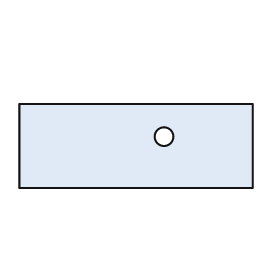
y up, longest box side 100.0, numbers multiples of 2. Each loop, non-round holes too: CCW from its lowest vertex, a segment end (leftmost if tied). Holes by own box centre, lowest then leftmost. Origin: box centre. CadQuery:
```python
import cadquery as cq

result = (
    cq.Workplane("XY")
    .moveTo(-50.0, -18.0)
    .lineTo(50.0, -18.0)
    .lineTo(50.0, 18.0)
    .lineTo(-50.0, 18.0)
    .close()
    .moveTo(12.0, 4.0)
    .circle(4.0)
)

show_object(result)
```